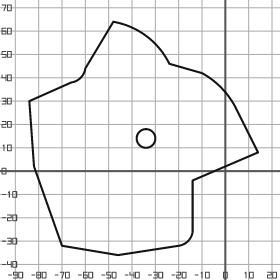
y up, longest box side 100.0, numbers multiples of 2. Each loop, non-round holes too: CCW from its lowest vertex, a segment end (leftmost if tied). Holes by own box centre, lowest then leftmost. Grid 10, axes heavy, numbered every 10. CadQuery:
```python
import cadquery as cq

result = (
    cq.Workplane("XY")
    .moveTo(-46.0, -36.0)
    .lineTo(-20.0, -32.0)
    .threePointArc((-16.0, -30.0), (-14.0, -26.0))
    .lineTo(-14.0, -4.0)
    .lineTo(14.0, 8.0)
    .lineTo(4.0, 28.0)
    .threePointArc((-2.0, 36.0), (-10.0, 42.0))
    .lineTo(-24.0, 46.0)
    .threePointArc((-34.0, 58.0), (-48.0, 64.0))
    .lineTo(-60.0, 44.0)
    .threePointArc((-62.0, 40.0), (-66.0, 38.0))
    .lineTo(-84.0, 30.0)
    .lineTo(-82.0, 2.0)
    .lineTo(-70.0, -32.0)
    .close()
    .moveTo(-34.0, 14.0)
    .circle(4.0)
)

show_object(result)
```